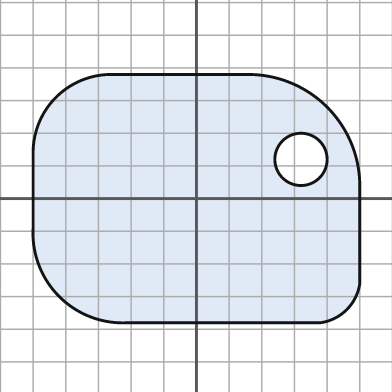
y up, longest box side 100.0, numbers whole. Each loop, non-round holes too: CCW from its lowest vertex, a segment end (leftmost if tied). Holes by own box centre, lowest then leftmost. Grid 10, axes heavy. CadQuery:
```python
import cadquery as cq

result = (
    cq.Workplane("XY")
    .moveTo(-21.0, -38.0)
    .lineTo(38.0, -38.0)
    .threePointArc((46.0, -34.0), (50.0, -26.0))
    .lineTo(50.0, 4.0)
    .threePointArc((40.0, 28.0), (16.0, 38.0))
    .lineTo(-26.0, 38.0)
    .threePointArc((-43.0, 31.0), (-50.0, 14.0))
    .lineTo(-50.0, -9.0)
    .threePointArc((-42.0, -30.0), (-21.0, -38.0))
    .close()
    .moveTo(32.0, 12.0)
    .circle(8.0)
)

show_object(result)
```